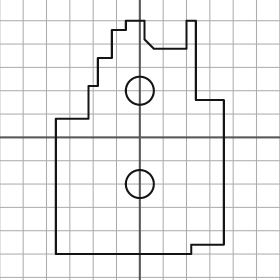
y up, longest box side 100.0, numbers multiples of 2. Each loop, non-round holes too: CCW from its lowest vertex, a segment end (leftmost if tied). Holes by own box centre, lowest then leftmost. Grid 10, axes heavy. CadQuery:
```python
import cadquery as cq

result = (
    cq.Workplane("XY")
    .moveTo(-36.0, -50.0)
    .lineTo(22.0, -50.0)
    .lineTo(22.0, -46.0)
    .lineTo(36.0, -46.0)
    .lineTo(36.0, 16.0)
    .lineTo(24.0, 16.0)
    .lineTo(24.0, 50.0)
    .lineTo(20.0, 50.0)
    .lineTo(20.0, 38.0)
    .lineTo(6.0, 38.0)
    .lineTo(2.0, 42.0)
    .lineTo(2.0, 50.0)
    .lineTo(-6.0, 50.0)
    .lineTo(-6.0, 46.0)
    .lineTo(-12.0, 46.0)
    .lineTo(-12.0, 34.0)
    .lineTo(-18.0, 34.0)
    .lineTo(-18.0, 22.0)
    .lineTo(-22.0, 22.0)
    .lineTo(-22.0, 8.0)
    .lineTo(-36.0, 8.0)
    .close()
    .moveTo(0.0, -20.0)
    .circle(6.0)
    .moveTo(0.0, 20.0)
    .circle(6.0)
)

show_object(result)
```